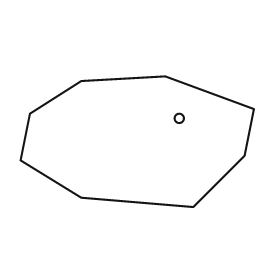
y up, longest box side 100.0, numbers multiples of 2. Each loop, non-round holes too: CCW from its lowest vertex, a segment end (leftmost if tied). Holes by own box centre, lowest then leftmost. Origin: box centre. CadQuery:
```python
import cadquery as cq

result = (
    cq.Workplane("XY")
    .moveTo(24.0, -28.0)
    .lineTo(46.0, -6.0)
    .lineTo(50.0, 14.0)
    .lineTo(12.0, 28.0)
    .lineTo(-24.0, 26.0)
    .lineTo(-46.0, 12.0)
    .lineTo(-50.0, -8.0)
    .lineTo(-24.0, -24.0)
    .close()
    .moveTo(18.0, 10.0)
    .circle(2.0)
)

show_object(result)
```